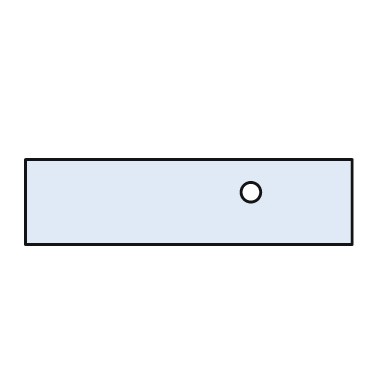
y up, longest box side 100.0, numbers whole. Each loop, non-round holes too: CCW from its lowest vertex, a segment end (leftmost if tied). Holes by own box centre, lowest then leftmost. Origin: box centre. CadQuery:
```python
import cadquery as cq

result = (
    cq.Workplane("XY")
    .moveTo(-50.0, -13.0)
    .lineTo(50.0, -13.0)
    .lineTo(50.0, 13.0)
    .lineTo(-50.0, 13.0)
    .close()
    .moveTo(19.0, 3.0)
    .circle(3.0)
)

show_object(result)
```